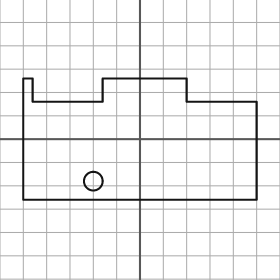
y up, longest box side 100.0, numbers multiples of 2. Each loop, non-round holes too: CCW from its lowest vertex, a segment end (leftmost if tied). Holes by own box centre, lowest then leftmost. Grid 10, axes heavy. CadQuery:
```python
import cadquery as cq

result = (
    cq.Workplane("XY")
    .moveTo(-50.0, -26.0)
    .lineTo(50.0, -26.0)
    .lineTo(50.0, 16.0)
    .lineTo(20.0, 16.0)
    .lineTo(20.0, 26.0)
    .lineTo(-16.0, 26.0)
    .lineTo(-16.0, 16.0)
    .lineTo(-46.0, 16.0)
    .lineTo(-46.0, 26.0)
    .lineTo(-50.0, 26.0)
    .close()
    .moveTo(-20.0, -18.0)
    .circle(4.0)
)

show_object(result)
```